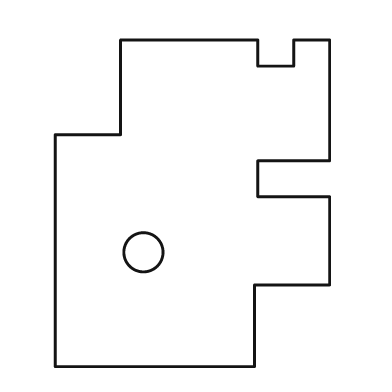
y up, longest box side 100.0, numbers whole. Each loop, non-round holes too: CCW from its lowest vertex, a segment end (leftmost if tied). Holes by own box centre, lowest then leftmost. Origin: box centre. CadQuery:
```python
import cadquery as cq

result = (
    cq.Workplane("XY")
    .moveTo(-42.0, -50.0)
    .lineTo(19.0, -50.0)
    .lineTo(19.0, -25.0)
    .lineTo(42.0, -25.0)
    .lineTo(42.0, 2.0)
    .lineTo(20.0, 2.0)
    .lineTo(20.0, 13.0)
    .lineTo(42.0, 13.0)
    .lineTo(42.0, 50.0)
    .lineTo(31.0, 50.0)
    .lineTo(31.0, 42.0)
    .lineTo(20.0, 42.0)
    .lineTo(20.0, 50.0)
    .lineTo(-22.0, 50.0)
    .lineTo(-22.0, 21.0)
    .lineTo(-42.0, 21.0)
    .close()
    .moveTo(-15.0, -15.0)
    .circle(6.0)
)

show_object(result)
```